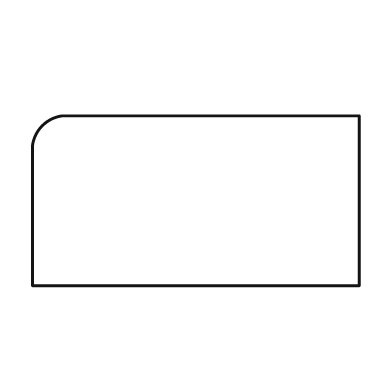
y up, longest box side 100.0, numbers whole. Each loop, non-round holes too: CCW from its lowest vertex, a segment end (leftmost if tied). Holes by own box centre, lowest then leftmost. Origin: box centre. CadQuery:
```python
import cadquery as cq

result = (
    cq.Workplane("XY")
    .moveTo(-50.0, -26.0)
    .lineTo(50.0, -26.0)
    .lineTo(50.0, 26.0)
    .lineTo(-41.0, 26.0)
    .threePointArc((-47.0, 23.0), (-50.0, 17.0))
    .close()
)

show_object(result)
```